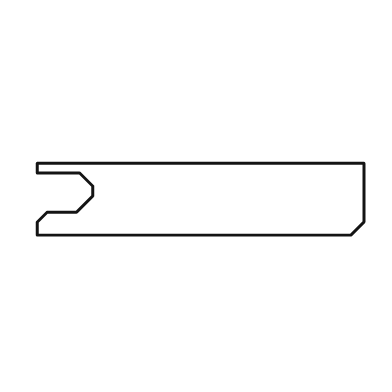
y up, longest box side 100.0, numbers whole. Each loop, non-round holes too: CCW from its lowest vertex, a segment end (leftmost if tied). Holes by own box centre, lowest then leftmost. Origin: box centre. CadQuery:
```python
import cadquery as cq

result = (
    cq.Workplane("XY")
    .moveTo(-50.0, -11.0)
    .lineTo(46.0, -11.0)
    .lineTo(50.0, -7.0)
    .lineTo(50.0, 11.0)
    .lineTo(-50.0, 11.0)
    .lineTo(-50.0, 8.0)
    .lineTo(-37.0, 8.0)
    .lineTo(-33.0, 4.0)
    .lineTo(-33.0, 1.0)
    .lineTo(-38.0, -4.0)
    .lineTo(-47.0, -4.0)
    .lineTo(-50.0, -7.0)
    .close()
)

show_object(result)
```